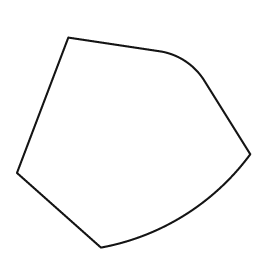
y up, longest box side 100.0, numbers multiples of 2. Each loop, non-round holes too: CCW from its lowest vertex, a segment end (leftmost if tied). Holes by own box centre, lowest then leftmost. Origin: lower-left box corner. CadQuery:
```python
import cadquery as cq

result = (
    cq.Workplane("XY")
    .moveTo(36.0, 0.0)
    .threePointArc((72.0, 14.0), (100.0, 40.0))
    .lineTo(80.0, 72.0)
    .threePointArc((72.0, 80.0), (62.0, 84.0))
    .lineTo(22.0, 90.0)
    .lineTo(0.0, 32.0)
    .close()
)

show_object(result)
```